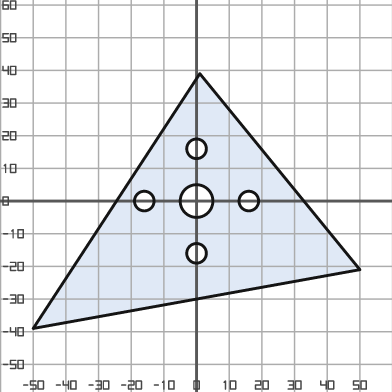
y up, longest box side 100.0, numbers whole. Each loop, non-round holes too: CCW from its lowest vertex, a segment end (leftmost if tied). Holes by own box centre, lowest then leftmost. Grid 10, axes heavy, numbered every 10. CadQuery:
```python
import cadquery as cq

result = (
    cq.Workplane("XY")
    .moveTo(-50.0, -39.0)
    .lineTo(50.0, -21.0)
    .lineTo(1.0, 39.0)
    .close()
    .moveTo(0.0, -16.0)
    .circle(3.0)
    .moveTo(-16.0, 0.0)
    .circle(3.0)
    .moveTo(0.0, 0.0)
    .circle(5.0)
    .moveTo(16.0, 0.0)
    .circle(3.0)
    .moveTo(0.0, 16.0)
    .circle(3.0)
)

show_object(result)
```